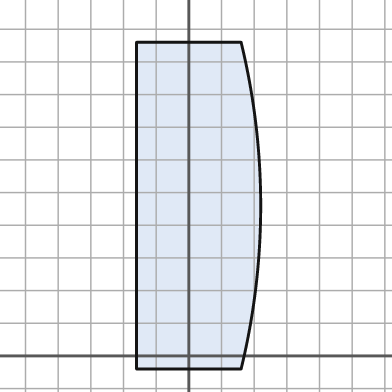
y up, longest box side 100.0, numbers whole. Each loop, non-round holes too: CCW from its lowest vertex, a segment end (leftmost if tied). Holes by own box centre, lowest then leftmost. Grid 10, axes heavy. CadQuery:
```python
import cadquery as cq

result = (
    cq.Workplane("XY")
    .moveTo(-16.0, -4.0)
    .lineTo(16.0, -4.0)
    .threePointArc((22.0, 46.0), (16.0, 96.0))
    .lineTo(-16.0, 96.0)
    .close()
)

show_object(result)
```